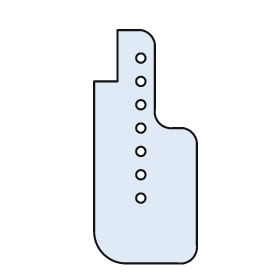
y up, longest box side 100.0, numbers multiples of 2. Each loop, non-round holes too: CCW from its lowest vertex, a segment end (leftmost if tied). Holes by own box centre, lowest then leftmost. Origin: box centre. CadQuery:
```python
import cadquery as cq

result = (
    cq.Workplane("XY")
    .moveTo(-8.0, -50.0)
    .lineTo(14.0, -50.0)
    .threePointArc((20.0, -48.0), (22.0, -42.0))
    .lineTo(22.0, 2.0)
    .threePointArc((20.0, 6.0), (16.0, 8.0))
    .lineTo(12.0, 8.0)
    .threePointArc((6.0, 10.0), (4.0, 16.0))
    .lineTo(4.0, 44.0)
    .threePointArc((2.0, 48.0), (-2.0, 50.0))
    .lineTo(-12.0, 50.0)
    .lineTo(-12.0, 28.0)
    .lineTo(-22.0, 28.0)
    .lineTo(-22.0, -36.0)
    .threePointArc((-18.0, -46.0), (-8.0, -50.0))
    .close()
    .moveTo(-2.0, -22.0)
    .circle(2.0)
    .moveTo(-2.0, -12.0)
    .circle(2.0)
    .moveTo(-2.0, -2.0)
    .circle(2.0)
    .moveTo(-2.0, 8.0)
    .circle(2.0)
    .moveTo(-2.0, 18.0)
    .circle(2.0)
    .moveTo(-2.0, 28.0)
    .circle(2.0)
    .moveTo(-2.0, 38.0)
    .circle(2.0)
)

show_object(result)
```